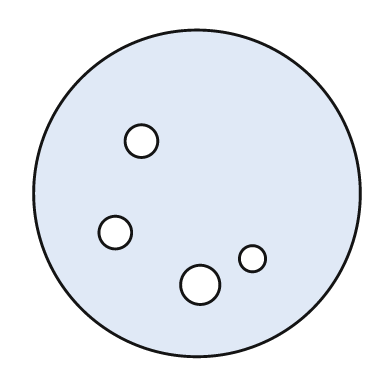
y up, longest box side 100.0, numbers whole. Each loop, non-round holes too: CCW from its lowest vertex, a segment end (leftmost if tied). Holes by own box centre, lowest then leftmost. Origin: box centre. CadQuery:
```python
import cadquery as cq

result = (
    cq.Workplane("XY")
    .moveTo(0.0, 0.0)
    .circle(50.0)
    .moveTo(1.0, -28.0)
    .circle(6.0)
    .moveTo(17.0, -20.0)
    .circle(4.0)
    .moveTo(-25.0, -12.0)
    .circle(5.0)
    .moveTo(-17.0, 16.0)
    .circle(5.0)
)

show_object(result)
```